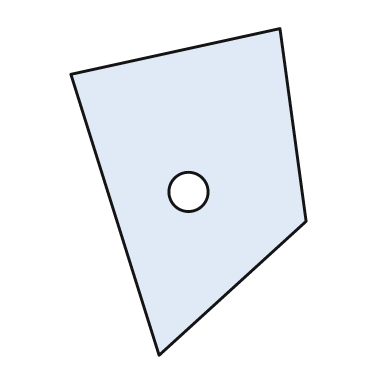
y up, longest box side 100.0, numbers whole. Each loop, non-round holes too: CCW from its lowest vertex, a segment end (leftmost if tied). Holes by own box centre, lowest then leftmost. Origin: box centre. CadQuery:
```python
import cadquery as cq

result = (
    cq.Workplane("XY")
    .moveTo(-9.0, -50.0)
    .lineTo(36.0, -9.0)
    .lineTo(28.0, 50.0)
    .lineTo(-36.0, 36.0)
    .close()
    .moveTo(0.0, 0.0)
    .circle(6.0)
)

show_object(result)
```